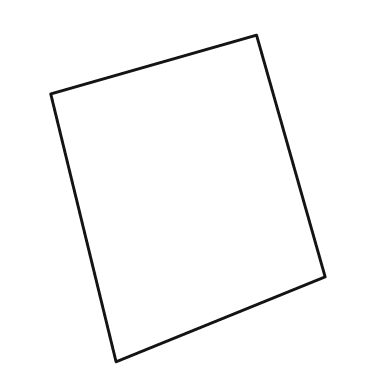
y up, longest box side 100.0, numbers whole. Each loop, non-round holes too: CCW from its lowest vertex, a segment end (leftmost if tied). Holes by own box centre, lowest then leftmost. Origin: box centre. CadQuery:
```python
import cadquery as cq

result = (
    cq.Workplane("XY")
    .moveTo(-22.0, -50.0)
    .lineTo(42.0, -24.0)
    .lineTo(21.0, 50.0)
    .lineTo(-42.0, 32.0)
    .close()
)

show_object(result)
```